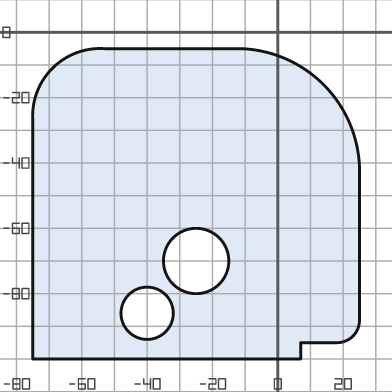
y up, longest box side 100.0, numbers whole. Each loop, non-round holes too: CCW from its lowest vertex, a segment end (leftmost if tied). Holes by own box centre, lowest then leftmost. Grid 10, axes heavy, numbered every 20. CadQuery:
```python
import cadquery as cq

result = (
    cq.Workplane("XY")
    .moveTo(-75.0, -100.0)
    .lineTo(7.0, -100.0)
    .lineTo(7.0, -95.0)
    .lineTo(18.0, -95.0)
    .threePointArc((23.0, -93.0), (25.0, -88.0))
    .lineTo(25.0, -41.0)
    .threePointArc((14.0, -16.0), (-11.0, -5.0))
    .lineTo(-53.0, -5.0)
    .threePointArc((-69.0, -11.0), (-75.0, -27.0))
    .close()
    .moveTo(-40.0, -86.0)
    .circle(8.0)
    .moveTo(-25.0, -70.0)
    .circle(10.0)
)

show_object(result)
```